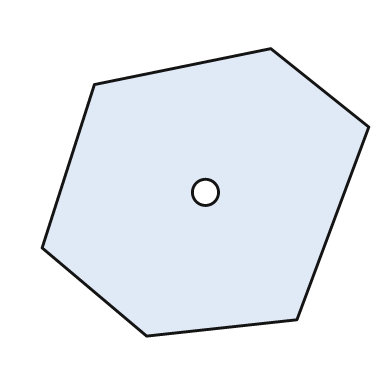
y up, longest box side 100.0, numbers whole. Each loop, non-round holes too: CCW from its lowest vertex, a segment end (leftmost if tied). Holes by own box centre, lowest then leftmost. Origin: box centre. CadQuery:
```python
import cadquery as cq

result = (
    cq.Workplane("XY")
    .moveTo(-18.0, -44.0)
    .lineTo(28.0, -39.0)
    .lineTo(50.0, 20.0)
    .lineTo(20.0, 44.0)
    .lineTo(-34.0, 33.0)
    .lineTo(-50.0, -17.0)
    .close()
    .moveTo(0.0, 0.0)
    .circle(4.0)
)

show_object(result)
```